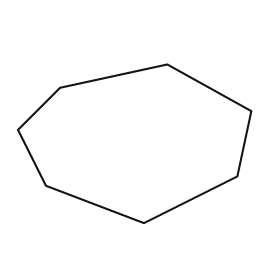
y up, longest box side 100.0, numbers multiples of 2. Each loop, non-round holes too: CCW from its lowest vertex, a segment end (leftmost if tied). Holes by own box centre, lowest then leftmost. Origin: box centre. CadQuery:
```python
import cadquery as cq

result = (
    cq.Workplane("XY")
    .moveTo(4.0, -34.0)
    .lineTo(44.0, -14.0)
    .lineTo(50.0, 14.0)
    .lineTo(14.0, 34.0)
    .lineTo(-32.0, 24.0)
    .lineTo(-50.0, 6.0)
    .lineTo(-38.0, -18.0)
    .close()
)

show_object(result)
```